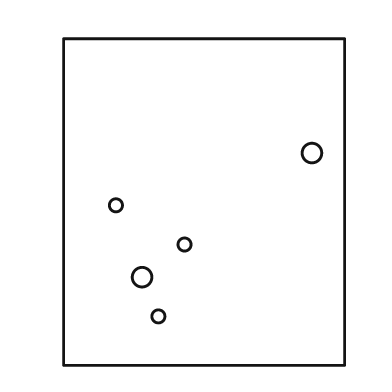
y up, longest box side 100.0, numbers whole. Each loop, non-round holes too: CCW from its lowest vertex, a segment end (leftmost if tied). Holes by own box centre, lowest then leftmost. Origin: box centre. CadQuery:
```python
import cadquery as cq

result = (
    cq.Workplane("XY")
    .moveTo(-43.0, -50.0)
    .lineTo(43.0, -50.0)
    .lineTo(43.0, 50.0)
    .lineTo(-43.0, 50.0)
    .close()
    .moveTo(-14.0, -35.0)
    .circle(2.0)
    .moveTo(-19.0, -23.0)
    .circle(3.0)
    .moveTo(-6.0, -13.0)
    .circle(2.0)
    .moveTo(-27.0, -1.0)
    .circle(2.0)
    .moveTo(33.0, 15.0)
    .circle(3.0)
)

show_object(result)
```